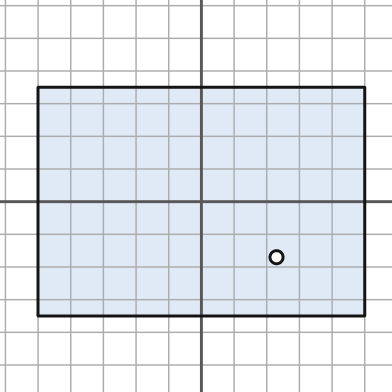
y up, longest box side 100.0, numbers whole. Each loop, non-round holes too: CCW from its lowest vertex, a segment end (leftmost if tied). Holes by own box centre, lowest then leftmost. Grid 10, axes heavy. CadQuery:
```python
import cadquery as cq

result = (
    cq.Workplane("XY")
    .moveTo(-50.0, -35.0)
    .lineTo(50.0, -35.0)
    .lineTo(50.0, 35.0)
    .lineTo(-50.0, 35.0)
    .close()
    .moveTo(23.0, -17.0)
    .circle(2.0)
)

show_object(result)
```